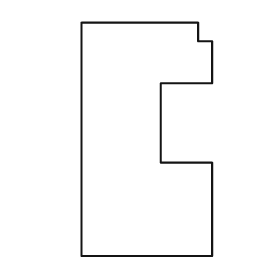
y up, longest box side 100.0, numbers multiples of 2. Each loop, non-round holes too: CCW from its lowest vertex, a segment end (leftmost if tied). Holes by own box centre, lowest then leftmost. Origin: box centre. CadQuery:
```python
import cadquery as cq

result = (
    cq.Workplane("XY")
    .moveTo(-28.0, -50.0)
    .lineTo(28.0, -50.0)
    .lineTo(28.0, -10.0)
    .lineTo(6.0, -10.0)
    .lineTo(6.0, 24.0)
    .lineTo(28.0, 24.0)
    .lineTo(28.0, 42.0)
    .lineTo(22.0, 42.0)
    .lineTo(22.0, 50.0)
    .lineTo(-28.0, 50.0)
    .close()
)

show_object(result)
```